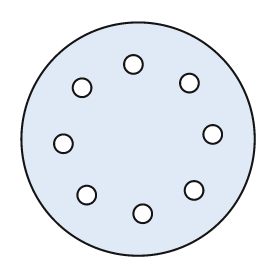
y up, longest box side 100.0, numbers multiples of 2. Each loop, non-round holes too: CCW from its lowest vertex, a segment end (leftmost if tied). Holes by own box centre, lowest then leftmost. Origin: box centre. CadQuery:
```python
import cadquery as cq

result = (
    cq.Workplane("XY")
    .moveTo(0.0, 0.0)
    .circle(50.0)
    .moveTo(2.0, -32.0)
    .circle(4.0)
    .moveTo(-22.0, -24.0)
    .circle(4.0)
    .moveTo(24.0, -22.0)
    .circle(4.0)
    .moveTo(-32.0, -2.0)
    .circle(4.0)
    .moveTo(32.0, 2.0)
    .circle(4.0)
    .moveTo(-24.0, 22.0)
    .circle(4.0)
    .moveTo(22.0, 24.0)
    .circle(4.0)
    .moveTo(-2.0, 32.0)
    .circle(4.0)
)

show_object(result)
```